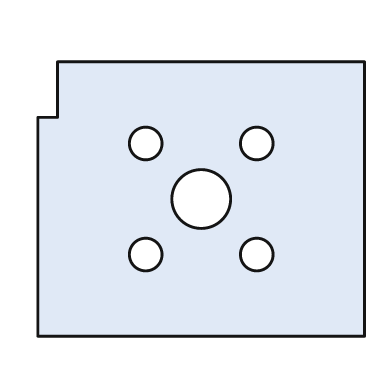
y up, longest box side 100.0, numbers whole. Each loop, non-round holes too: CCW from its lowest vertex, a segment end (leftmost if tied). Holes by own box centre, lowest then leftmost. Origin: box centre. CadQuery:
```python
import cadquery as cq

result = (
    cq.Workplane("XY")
    .moveTo(-50.0, -42.0)
    .lineTo(50.0, -42.0)
    .lineTo(50.0, 42.0)
    .lineTo(-44.0, 42.0)
    .lineTo(-44.0, 25.0)
    .lineTo(-50.0, 25.0)
    .close()
    .moveTo(-17.0, -17.0)
    .circle(5.0)
    .moveTo(17.0, -17.0)
    .circle(5.0)
    .moveTo(0.0, 0.0)
    .circle(9.0)
    .moveTo(-17.0, 17.0)
    .circle(5.0)
    .moveTo(17.0, 17.0)
    .circle(5.0)
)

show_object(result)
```